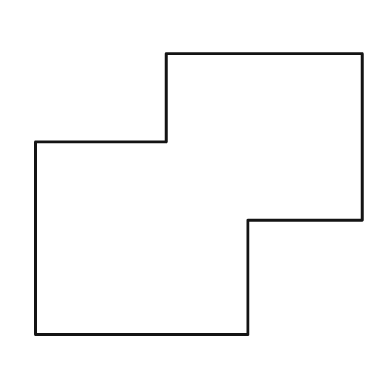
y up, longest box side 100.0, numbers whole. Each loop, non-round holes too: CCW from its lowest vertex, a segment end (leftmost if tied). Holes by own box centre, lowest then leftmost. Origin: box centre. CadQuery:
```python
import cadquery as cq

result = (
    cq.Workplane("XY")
    .moveTo(-50.0, -43.0)
    .lineTo(15.0, -43.0)
    .lineTo(15.0, -8.0)
    .lineTo(50.0, -8.0)
    .lineTo(50.0, 43.0)
    .lineTo(-10.0, 43.0)
    .lineTo(-10.0, 16.0)
    .lineTo(-50.0, 16.0)
    .close()
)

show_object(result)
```